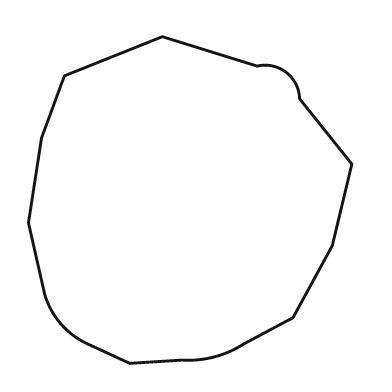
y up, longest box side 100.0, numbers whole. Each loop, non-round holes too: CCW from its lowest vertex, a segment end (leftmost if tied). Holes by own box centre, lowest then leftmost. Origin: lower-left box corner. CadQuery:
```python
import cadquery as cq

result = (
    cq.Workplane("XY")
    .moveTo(31.0, 0.0)
    .lineTo(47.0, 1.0)
    .threePointArc((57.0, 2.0), (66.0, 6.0))
    .lineTo(81.0, 14.0)
    .lineTo(93.0, 36.0)
    .lineTo(99.0, 61.0)
    .lineTo(83.0, 81.0)
    .threePointArc((79.0, 89.0), (70.0, 91.0))
    .lineTo(41.0, 100.0)
    .lineTo(11.0, 88.0)
    .lineTo(4.0, 69.0)
    .lineTo(0.0, 43.0)
    .lineTo(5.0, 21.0)
    .threePointArc((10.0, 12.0), (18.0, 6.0))
    .close()
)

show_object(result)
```